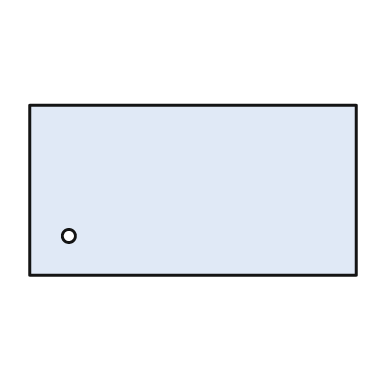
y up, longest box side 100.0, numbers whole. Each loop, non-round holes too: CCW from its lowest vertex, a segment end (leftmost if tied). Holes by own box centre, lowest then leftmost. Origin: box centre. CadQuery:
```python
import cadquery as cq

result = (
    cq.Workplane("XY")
    .moveTo(-50.0, -26.0)
    .lineTo(50.0, -26.0)
    .lineTo(50.0, 26.0)
    .lineTo(-50.0, 26.0)
    .close()
    .moveTo(-38.0, -14.0)
    .circle(2.0)
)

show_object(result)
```